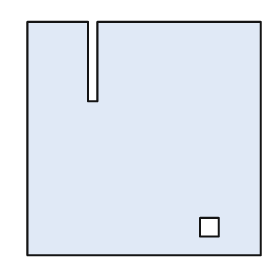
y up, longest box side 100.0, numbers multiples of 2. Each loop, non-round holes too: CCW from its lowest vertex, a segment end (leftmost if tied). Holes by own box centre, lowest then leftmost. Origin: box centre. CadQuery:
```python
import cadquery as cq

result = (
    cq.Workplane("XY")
    .moveTo(-50.0, -50.0)
    .lineTo(50.0, -50.0)
    .lineTo(50.0, 50.0)
    .lineTo(-20.0, 50.0)
    .lineTo(-20.0, 16.0)
    .lineTo(-24.0, 16.0)
    .lineTo(-24.0, 50.0)
    .lineTo(-50.0, 50.0)
    .close()
    .moveTo(24.0, -42.0)
    .lineTo(32.0, -42.0)
    .lineTo(32.0, -34.0)
    .lineTo(24.0, -34.0)
    .close()
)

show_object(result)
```